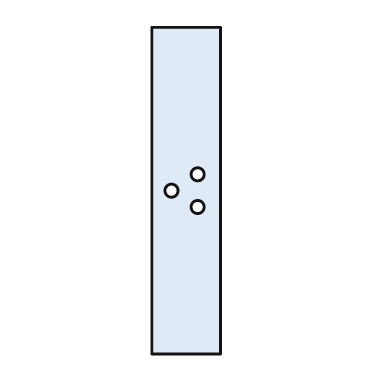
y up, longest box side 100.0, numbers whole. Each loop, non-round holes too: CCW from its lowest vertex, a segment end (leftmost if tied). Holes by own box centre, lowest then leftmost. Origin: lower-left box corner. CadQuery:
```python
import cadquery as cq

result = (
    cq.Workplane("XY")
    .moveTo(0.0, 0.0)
    .lineTo(21.0, 0.0)
    .lineTo(21.0, 100.0)
    .lineTo(0.0, 100.0)
    .close()
    .moveTo(14.0, 45.0)
    .circle(2.0)
    .moveTo(6.0, 50.0)
    .circle(2.0)
    .moveTo(14.0, 55.0)
    .circle(2.0)
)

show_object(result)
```